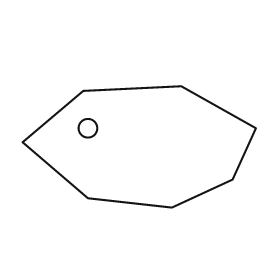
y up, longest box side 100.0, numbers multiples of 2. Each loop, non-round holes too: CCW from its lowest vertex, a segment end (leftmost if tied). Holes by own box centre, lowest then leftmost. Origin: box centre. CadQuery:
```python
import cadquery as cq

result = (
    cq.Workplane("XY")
    .moveTo(14.0, -26.0)
    .lineTo(40.0, -14.0)
    .lineTo(50.0, 8.0)
    .lineTo(18.0, 26.0)
    .lineTo(-24.0, 24.0)
    .lineTo(-50.0, 2.0)
    .lineTo(-22.0, -22.0)
    .close()
    .moveTo(-22.0, 8.0)
    .circle(4.0)
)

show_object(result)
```